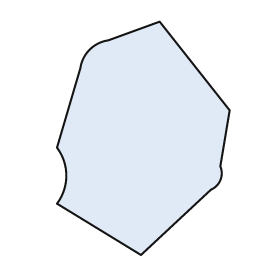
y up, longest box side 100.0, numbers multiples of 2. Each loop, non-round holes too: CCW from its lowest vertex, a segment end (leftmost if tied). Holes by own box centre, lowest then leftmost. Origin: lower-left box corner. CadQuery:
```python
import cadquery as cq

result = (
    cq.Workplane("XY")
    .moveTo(36.0, 0.0)
    .lineTo(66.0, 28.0)
    .threePointArc((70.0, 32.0), (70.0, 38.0))
    .lineTo(74.0, 62.0)
    .lineTo(44.0, 100.0)
    .lineTo(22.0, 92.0)
    .threePointArc((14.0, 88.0), (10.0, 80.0))
    .lineTo(0.0, 46.0)
    .threePointArc((4.0, 34.0), (0.0, 22.0))
    .close()
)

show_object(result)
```